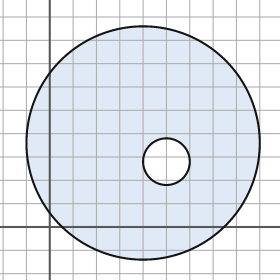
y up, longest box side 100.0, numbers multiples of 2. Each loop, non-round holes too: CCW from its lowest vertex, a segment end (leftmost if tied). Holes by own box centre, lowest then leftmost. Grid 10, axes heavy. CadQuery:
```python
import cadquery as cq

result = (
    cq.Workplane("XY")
    .moveTo(40.0, 36.0)
    .circle(50.0)
    .moveTo(50.0, 28.0)
    .circle(10.0)
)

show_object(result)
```